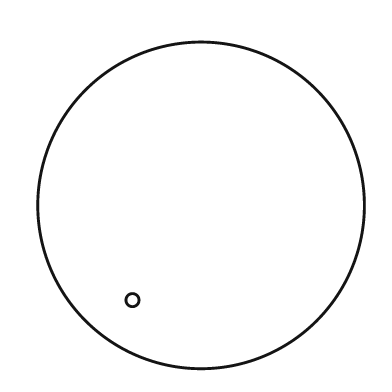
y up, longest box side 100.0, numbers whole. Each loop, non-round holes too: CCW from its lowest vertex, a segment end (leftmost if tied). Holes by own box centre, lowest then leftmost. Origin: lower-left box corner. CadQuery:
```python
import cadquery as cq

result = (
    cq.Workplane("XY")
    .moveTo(50.0, 50.0)
    .circle(50.0)
    .moveTo(29.0, 21.0)
    .circle(2.0)
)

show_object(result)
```